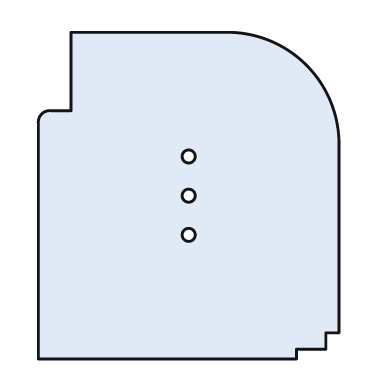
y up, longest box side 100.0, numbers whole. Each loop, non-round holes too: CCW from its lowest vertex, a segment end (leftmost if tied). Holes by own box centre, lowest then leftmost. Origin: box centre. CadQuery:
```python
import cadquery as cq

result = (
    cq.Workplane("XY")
    .moveTo(-46.0, -50.0)
    .lineTo(33.0, -50.0)
    .lineTo(33.0, -47.0)
    .lineTo(42.0, -47.0)
    .lineTo(42.0, -42.0)
    .lineTo(46.0, -42.0)
    .lineTo(46.0, 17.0)
    .threePointArc((36.0, 40.0), (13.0, 50.0))
    .lineTo(-36.0, 50.0)
    .lineTo(-36.0, 26.0)
    .lineTo(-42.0, 26.0)
    .threePointArc((-45.0, 25.0), (-46.0, 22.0))
    .close()
    .moveTo(0.0, -12.0)
    .circle(2.0)
    .moveTo(0.0, 0.0)
    .circle(2.0)
    .moveTo(0.0, 12.0)
    .circle(2.0)
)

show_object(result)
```